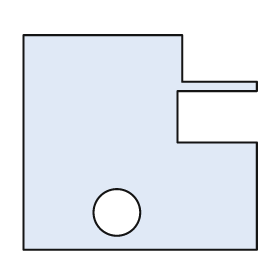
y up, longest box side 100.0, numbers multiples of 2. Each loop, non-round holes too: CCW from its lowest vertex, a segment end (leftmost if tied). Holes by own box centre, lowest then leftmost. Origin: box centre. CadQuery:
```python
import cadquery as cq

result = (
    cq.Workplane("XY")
    .moveTo(-50.0, -46.0)
    .lineTo(50.0, -46.0)
    .lineTo(50.0, 0.0)
    .lineTo(16.0, 0.0)
    .lineTo(16.0, 22.0)
    .lineTo(50.0, 22.0)
    .lineTo(50.0, 26.0)
    .lineTo(18.0, 26.0)
    .lineTo(18.0, 46.0)
    .lineTo(-50.0, 46.0)
    .close()
    .moveTo(-10.0, -30.0)
    .circle(10.0)
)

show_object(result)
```